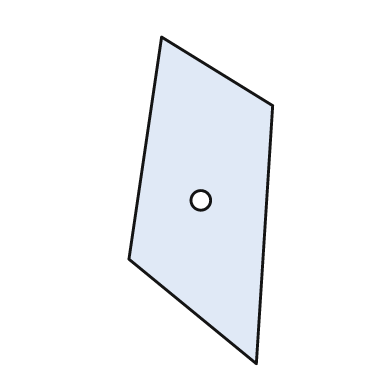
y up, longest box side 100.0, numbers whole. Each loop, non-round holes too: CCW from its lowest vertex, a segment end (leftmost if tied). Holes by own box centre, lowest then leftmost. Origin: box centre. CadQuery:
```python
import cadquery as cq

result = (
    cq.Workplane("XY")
    .moveTo(17.0, -50.0)
    .lineTo(22.0, 29.0)
    .lineTo(-12.0, 50.0)
    .lineTo(-22.0, -18.0)
    .close()
    .moveTo(0.0, 0.0)
    .circle(3.0)
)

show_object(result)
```